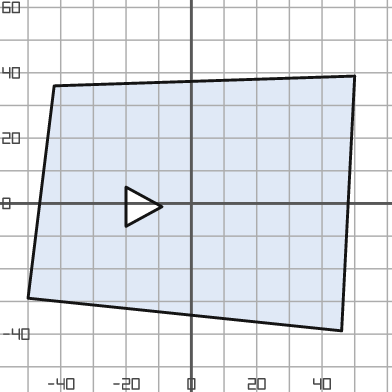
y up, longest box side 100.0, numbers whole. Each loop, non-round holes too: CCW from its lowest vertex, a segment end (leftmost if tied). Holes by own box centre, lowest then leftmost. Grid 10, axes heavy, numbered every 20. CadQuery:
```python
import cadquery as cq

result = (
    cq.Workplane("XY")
    .moveTo(46.0, -39.0)
    .lineTo(50.0, 39.0)
    .lineTo(-42.0, 36.0)
    .lineTo(-50.0, -29.0)
    .close()
    .moveTo(-20.0, -7.0)
    .lineTo(-9.0, -1.0)
    .lineTo(-20.0, 5.0)
    .close()
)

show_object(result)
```